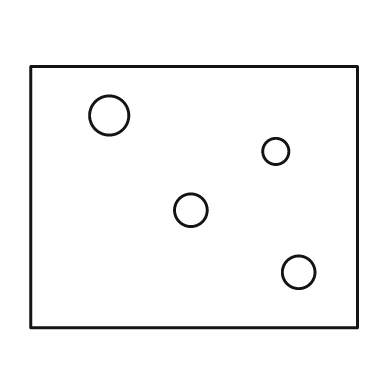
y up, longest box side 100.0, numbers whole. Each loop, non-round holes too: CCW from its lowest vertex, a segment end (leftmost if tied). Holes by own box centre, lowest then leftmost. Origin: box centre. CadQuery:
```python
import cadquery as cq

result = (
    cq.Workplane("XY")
    .moveTo(-50.0, -40.0)
    .lineTo(50.0, -40.0)
    .lineTo(50.0, 40.0)
    .lineTo(-50.0, 40.0)
    .close()
    .moveTo(32.0, -23.0)
    .circle(5.0)
    .moveTo(-1.0, -4.0)
    .circle(5.0)
    .moveTo(25.0, 14.0)
    .circle(4.0)
    .moveTo(-26.0, 25.0)
    .circle(6.0)
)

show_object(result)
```